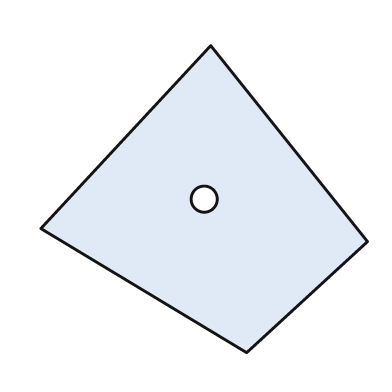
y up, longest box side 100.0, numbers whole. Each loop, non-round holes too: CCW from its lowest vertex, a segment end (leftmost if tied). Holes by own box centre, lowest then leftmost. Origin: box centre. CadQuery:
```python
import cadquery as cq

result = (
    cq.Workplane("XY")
    .moveTo(13.0, -47.0)
    .lineTo(50.0, -13.0)
    .lineTo(2.0, 47.0)
    .lineTo(-50.0, -9.0)
    .close()
    .moveTo(0.0, 0.0)
    .circle(4.0)
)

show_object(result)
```